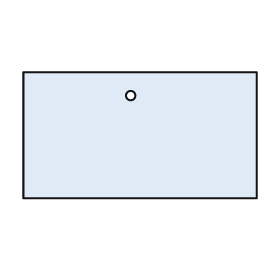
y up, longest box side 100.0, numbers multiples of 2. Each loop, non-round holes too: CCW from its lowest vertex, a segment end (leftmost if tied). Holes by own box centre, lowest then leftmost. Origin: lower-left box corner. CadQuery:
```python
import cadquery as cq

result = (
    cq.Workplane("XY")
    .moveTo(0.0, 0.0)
    .lineTo(100.0, 0.0)
    .lineTo(100.0, 54.0)
    .lineTo(0.0, 54.0)
    .close()
    .moveTo(46.0, 44.0)
    .circle(2.0)
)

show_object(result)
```